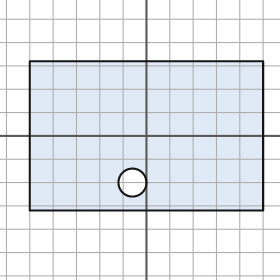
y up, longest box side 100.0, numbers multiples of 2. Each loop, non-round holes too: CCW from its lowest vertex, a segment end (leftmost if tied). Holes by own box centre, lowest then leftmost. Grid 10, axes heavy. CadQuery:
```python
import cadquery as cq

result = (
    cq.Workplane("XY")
    .moveTo(-50.0, -32.0)
    .lineTo(50.0, -32.0)
    .lineTo(50.0, 32.0)
    .lineTo(-50.0, 32.0)
    .close()
    .moveTo(-6.0, -20.0)
    .circle(6.0)
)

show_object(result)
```